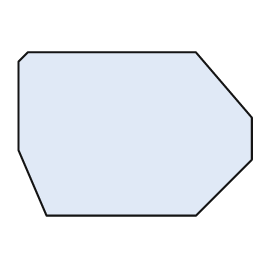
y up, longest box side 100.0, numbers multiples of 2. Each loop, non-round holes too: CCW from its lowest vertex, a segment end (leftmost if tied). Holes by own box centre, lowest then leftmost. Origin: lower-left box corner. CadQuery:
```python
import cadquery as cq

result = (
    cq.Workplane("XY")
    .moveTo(12.0, 0.0)
    .lineTo(76.0, 0.0)
    .lineTo(100.0, 24.0)
    .lineTo(100.0, 42.0)
    .lineTo(76.0, 70.0)
    .lineTo(4.0, 70.0)
    .lineTo(0.0, 66.0)
    .lineTo(0.0, 28.0)
    .close()
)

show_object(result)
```